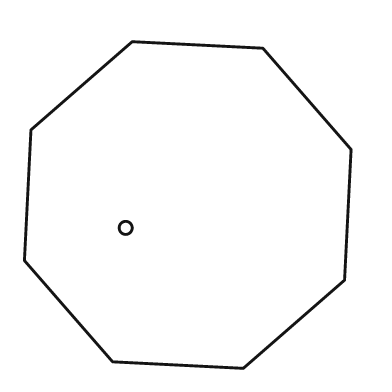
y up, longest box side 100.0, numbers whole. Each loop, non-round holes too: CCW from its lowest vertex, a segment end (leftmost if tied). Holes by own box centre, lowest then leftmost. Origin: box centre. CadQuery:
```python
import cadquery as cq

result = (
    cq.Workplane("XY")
    .moveTo(17.0, -50.0)
    .lineTo(48.0, -23.0)
    .lineTo(50.0, 17.0)
    .lineTo(23.0, 48.0)
    .lineTo(-17.0, 50.0)
    .lineTo(-48.0, 23.0)
    .lineTo(-50.0, -17.0)
    .lineTo(-23.0, -48.0)
    .close()
    .moveTo(-19.0, -7.0)
    .circle(2.0)
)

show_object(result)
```